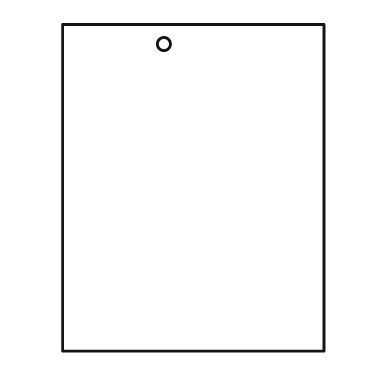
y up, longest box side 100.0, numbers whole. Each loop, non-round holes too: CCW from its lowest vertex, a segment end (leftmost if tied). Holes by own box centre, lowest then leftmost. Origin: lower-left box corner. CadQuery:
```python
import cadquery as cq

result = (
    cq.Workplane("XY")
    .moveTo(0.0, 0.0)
    .lineTo(80.0, 0.0)
    .lineTo(80.0, 100.0)
    .lineTo(0.0, 100.0)
    .close()
    .moveTo(31.0, 94.0)
    .circle(2.0)
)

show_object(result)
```